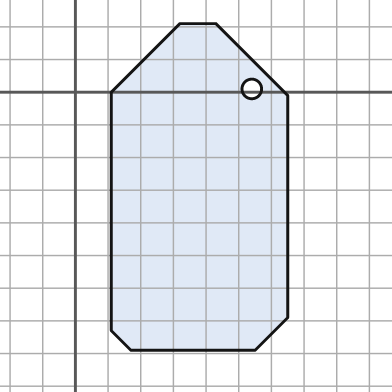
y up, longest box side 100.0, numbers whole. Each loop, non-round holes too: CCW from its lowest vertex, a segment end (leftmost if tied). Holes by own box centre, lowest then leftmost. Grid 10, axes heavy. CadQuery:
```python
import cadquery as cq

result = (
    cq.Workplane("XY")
    .moveTo(17.0, -79.0)
    .lineTo(55.0, -79.0)
    .lineTo(65.0, -69.0)
    .lineTo(65.0, -1.0)
    .lineTo(43.0, 21.0)
    .lineTo(32.0, 21.0)
    .lineTo(11.0, 0.0)
    .lineTo(11.0, -73.0)
    .close()
    .moveTo(54.0, 1.0)
    .circle(3.0)
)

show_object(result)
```